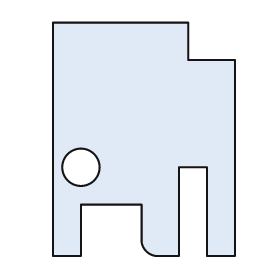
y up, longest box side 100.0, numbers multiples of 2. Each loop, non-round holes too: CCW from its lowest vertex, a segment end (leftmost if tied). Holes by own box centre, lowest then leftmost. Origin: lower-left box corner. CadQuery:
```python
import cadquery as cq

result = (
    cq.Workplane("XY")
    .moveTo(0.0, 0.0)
    .lineTo(12.0, 0.0)
    .lineTo(12.0, 22.0)
    .lineTo(38.0, 22.0)
    .lineTo(38.0, 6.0)
    .threePointArc((40.0, 2.0), (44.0, 0.0))
    .lineTo(54.0, 0.0)
    .lineTo(54.0, 38.0)
    .lineTo(66.0, 38.0)
    .lineTo(66.0, 0.0)
    .lineTo(78.0, 0.0)
    .lineTo(78.0, 84.0)
    .lineTo(58.0, 84.0)
    .lineTo(58.0, 100.0)
    .lineTo(0.0, 100.0)
    .close()
    .moveTo(12.0, 38.0)
    .circle(8.0)
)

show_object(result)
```